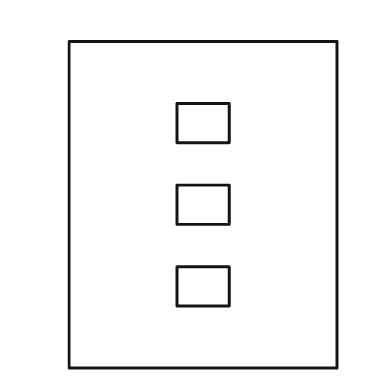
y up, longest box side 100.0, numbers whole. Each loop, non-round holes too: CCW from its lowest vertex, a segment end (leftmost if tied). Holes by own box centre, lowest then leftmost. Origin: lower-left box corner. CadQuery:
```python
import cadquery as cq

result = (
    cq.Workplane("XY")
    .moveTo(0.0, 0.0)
    .lineTo(82.0, 0.0)
    .lineTo(82.0, 100.0)
    .lineTo(0.0, 100.0)
    .close()
    .moveTo(33.0, 19.0)
    .lineTo(49.0, 19.0)
    .lineTo(49.0, 31.0)
    .lineTo(33.0, 31.0)
    .close()
    .moveTo(33.0, 44.0)
    .lineTo(49.0, 44.0)
    .lineTo(49.0, 56.0)
    .lineTo(33.0, 56.0)
    .close()
    .moveTo(33.0, 69.0)
    .lineTo(49.0, 69.0)
    .lineTo(49.0, 81.0)
    .lineTo(33.0, 81.0)
    .close()
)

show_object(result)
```